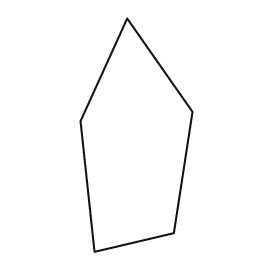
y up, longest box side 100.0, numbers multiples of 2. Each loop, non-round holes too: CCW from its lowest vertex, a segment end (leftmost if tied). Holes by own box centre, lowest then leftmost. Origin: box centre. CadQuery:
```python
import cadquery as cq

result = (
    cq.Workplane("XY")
    .moveTo(-18.0, -50.0)
    .lineTo(16.0, -42.0)
    .lineTo(24.0, 10.0)
    .lineTo(-4.0, 50.0)
    .lineTo(-24.0, 6.0)
    .close()
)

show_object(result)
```